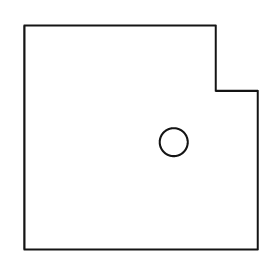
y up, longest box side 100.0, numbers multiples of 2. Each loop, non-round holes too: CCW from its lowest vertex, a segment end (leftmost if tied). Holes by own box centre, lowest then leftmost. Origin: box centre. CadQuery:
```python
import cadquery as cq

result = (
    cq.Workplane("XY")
    .moveTo(-50.0, -48.0)
    .lineTo(50.0, -48.0)
    .lineTo(50.0, 20.0)
    .lineTo(32.0, 20.0)
    .lineTo(32.0, 48.0)
    .lineTo(-50.0, 48.0)
    .close()
    .moveTo(14.0, -2.0)
    .circle(6.0)
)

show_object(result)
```